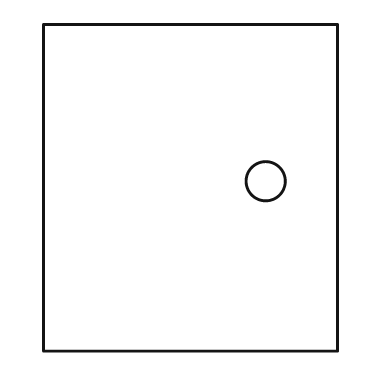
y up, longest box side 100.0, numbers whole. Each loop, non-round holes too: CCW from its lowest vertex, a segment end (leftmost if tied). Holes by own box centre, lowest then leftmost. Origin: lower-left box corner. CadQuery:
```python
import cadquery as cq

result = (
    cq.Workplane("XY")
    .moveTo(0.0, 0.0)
    .lineTo(90.0, 0.0)
    .lineTo(90.0, 100.0)
    .lineTo(0.0, 100.0)
    .close()
    .moveTo(68.0, 52.0)
    .circle(6.0)
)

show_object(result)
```